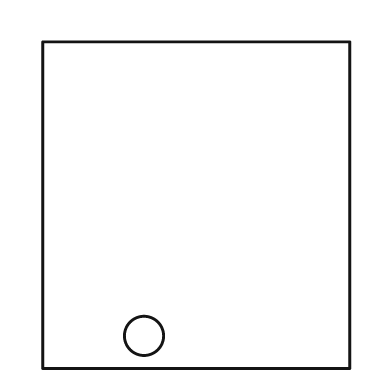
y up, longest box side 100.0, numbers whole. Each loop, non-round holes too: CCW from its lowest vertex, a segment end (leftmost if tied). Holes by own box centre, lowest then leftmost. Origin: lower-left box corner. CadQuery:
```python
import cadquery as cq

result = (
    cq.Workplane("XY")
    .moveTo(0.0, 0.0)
    .lineTo(94.0, 0.0)
    .lineTo(94.0, 100.0)
    .lineTo(0.0, 100.0)
    .close()
    .moveTo(31.0, 10.0)
    .circle(6.0)
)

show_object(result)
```